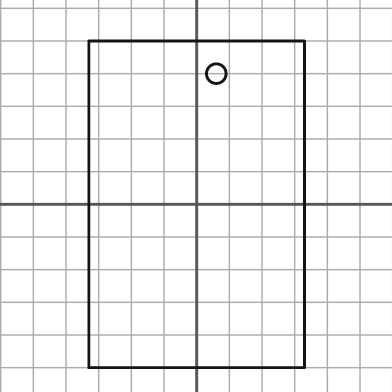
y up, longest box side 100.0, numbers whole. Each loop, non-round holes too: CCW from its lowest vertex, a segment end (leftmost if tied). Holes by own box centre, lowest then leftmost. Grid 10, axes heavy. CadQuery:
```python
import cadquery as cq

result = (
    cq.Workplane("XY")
    .moveTo(-33.0, -50.0)
    .lineTo(33.0, -50.0)
    .lineTo(33.0, 50.0)
    .lineTo(-33.0, 50.0)
    .close()
    .moveTo(6.0, 40.0)
    .circle(3.0)
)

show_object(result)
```